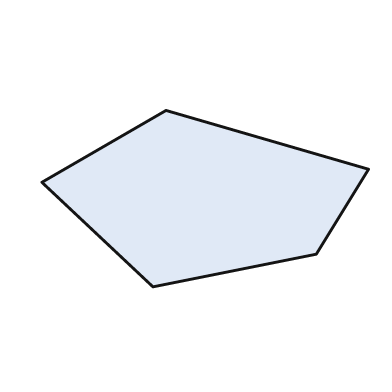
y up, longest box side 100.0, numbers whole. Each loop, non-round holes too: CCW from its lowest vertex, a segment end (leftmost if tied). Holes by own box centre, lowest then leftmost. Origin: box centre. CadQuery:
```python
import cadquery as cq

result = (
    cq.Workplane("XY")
    .moveTo(-16.0, -27.0)
    .lineTo(34.0, -17.0)
    .lineTo(50.0, 9.0)
    .lineTo(-12.0, 27.0)
    .lineTo(-50.0, 5.0)
    .close()
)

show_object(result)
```